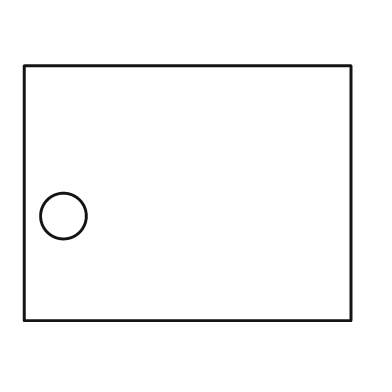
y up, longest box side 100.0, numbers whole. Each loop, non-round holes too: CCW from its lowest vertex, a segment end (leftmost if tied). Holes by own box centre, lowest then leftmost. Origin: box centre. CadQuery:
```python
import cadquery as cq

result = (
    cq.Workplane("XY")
    .moveTo(-50.0, -39.0)
    .lineTo(50.0, -39.0)
    .lineTo(50.0, 39.0)
    .lineTo(-50.0, 39.0)
    .close()
    .moveTo(-38.0, -7.0)
    .circle(7.0)
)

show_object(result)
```